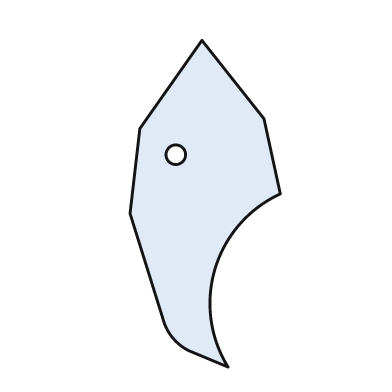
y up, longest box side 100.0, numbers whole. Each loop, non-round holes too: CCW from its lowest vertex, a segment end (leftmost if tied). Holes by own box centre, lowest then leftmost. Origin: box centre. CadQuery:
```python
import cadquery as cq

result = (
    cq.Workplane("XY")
    .moveTo(7.0, -50.0)
    .threePointArc((3.0, -20.0), (23.0, 3.0))
    .lineTo(18.0, 26.0)
    .lineTo(-1.0, 50.0)
    .lineTo(-20.0, 23.0)
    .lineTo(-23.0, -3.0)
    .lineTo(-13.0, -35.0)
    .threePointArc((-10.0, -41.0), (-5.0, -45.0))
    .close()
    .moveTo(-9.0, 15.0)
    .circle(3.0)
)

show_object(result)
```